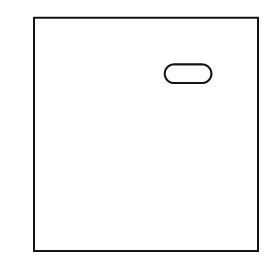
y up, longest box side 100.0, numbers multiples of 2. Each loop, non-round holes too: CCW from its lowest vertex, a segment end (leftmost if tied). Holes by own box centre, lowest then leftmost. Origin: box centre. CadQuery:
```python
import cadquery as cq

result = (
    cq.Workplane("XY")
    .moveTo(-48.0, -50.0)
    .lineTo(48.0, -50.0)
    .lineTo(48.0, 50.0)
    .lineTo(-48.0, 50.0)
    .close()
    .moveTo(12.0, 22.0)
    .lineTo(24.0, 22.0)
    .threePointArc((28.0, 26.0), (24.0, 30.0))
    .lineTo(12.0, 30.0)
    .threePointArc((8.0, 26.0), (12.0, 22.0))
    .close()
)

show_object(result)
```